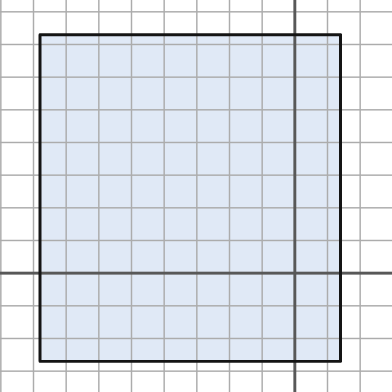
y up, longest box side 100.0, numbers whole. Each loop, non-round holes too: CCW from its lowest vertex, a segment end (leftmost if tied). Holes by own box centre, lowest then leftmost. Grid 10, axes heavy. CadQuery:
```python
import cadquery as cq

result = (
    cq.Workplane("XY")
    .moveTo(-78.0, -27.0)
    .lineTo(14.0, -27.0)
    .lineTo(14.0, 73.0)
    .lineTo(-78.0, 73.0)
    .close()
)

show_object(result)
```